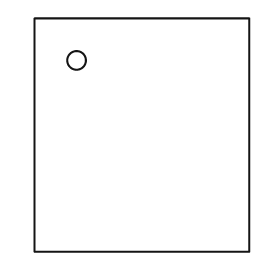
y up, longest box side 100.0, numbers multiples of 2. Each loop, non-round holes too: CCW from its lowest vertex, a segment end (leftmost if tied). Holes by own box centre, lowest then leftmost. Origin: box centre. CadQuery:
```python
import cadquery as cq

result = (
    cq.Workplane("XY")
    .moveTo(-46.0, -50.0)
    .lineTo(46.0, -50.0)
    .lineTo(46.0, 50.0)
    .lineTo(-46.0, 50.0)
    .close()
    .moveTo(-28.0, 32.0)
    .circle(4.0)
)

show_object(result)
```